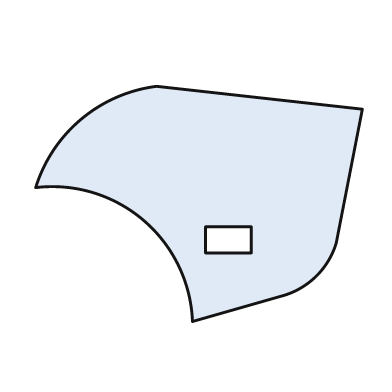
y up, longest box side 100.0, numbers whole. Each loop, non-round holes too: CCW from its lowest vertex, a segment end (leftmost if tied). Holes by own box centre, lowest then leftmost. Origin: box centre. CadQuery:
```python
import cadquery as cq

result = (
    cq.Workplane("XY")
    .moveTo(-2.0, -36.0)
    .lineTo(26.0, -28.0)
    .threePointArc((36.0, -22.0), (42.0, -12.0))
    .lineTo(50.0, 29.0)
    .lineTo(-13.0, 36.0)
    .threePointArc((-36.0, 26.0), (-50.0, 5.0))
    .threePointArc((-17.0, -5.0), (-2.0, -36.0))
    .close()
    .moveTo(2.0, -15.0)
    .lineTo(16.0, -15.0)
    .lineTo(16.0, -7.0)
    .lineTo(2.0, -7.0)
    .close()
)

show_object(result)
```